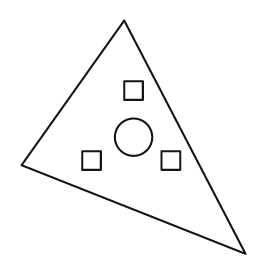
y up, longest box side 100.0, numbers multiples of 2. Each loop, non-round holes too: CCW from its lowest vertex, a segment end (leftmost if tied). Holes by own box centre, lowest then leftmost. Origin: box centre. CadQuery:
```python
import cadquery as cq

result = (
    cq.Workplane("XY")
    .moveTo(48.0, -50.0)
    .lineTo(-4.0, 50.0)
    .lineTo(-48.0, -12.0)
    .close()
    .moveTo(-22.0, -14.0)
    .lineTo(-14.0, -14.0)
    .lineTo(-14.0, -6.0)
    .lineTo(-22.0, -6.0)
    .close()
    .moveTo(12.0, -14.0)
    .lineTo(20.0, -14.0)
    .lineTo(20.0, -6.0)
    .lineTo(12.0, -6.0)
    .close()
    .moveTo(0.0, 0.0)
    .circle(8.0)
    .moveTo(-4.0, 16.0)
    .lineTo(4.0, 16.0)
    .lineTo(4.0, 24.0)
    .lineTo(-4.0, 24.0)
    .close()
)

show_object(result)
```